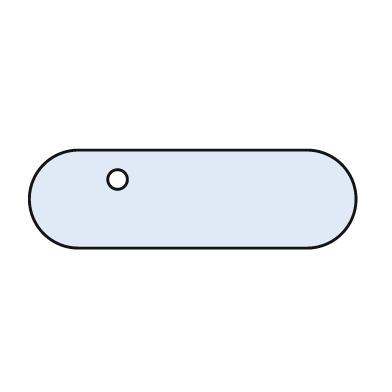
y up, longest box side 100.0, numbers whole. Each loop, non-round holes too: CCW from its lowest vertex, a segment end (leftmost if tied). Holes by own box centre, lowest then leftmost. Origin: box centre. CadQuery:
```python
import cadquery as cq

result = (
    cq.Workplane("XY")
    .moveTo(-35.0, -15.0)
    .lineTo(35.0, -15.0)
    .threePointArc((50.0, 0.0), (35.0, 15.0))
    .lineTo(-35.0, 15.0)
    .threePointArc((-50.0, 0.0), (-35.0, -15.0))
    .close()
    .moveTo(-23.0, 6.0)
    .circle(3.0)
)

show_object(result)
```